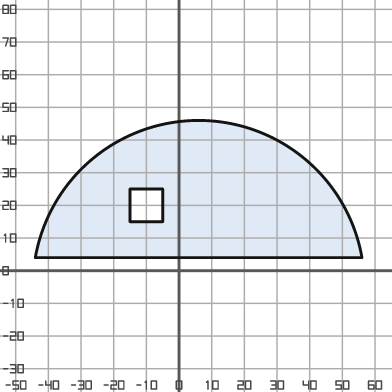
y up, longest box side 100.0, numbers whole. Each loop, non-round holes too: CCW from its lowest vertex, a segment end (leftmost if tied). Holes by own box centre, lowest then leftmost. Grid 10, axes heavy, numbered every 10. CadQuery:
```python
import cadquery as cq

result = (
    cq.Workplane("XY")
    .moveTo(-44.0, 4.0)
    .lineTo(56.0, 4.0)
    .threePointArc((6.0, 46.0), (-44.0, 4.0))
    .close()
    .moveTo(-15.0, 15.0)
    .lineTo(-5.0, 15.0)
    .lineTo(-5.0, 25.0)
    .lineTo(-15.0, 25.0)
    .close()
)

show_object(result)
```